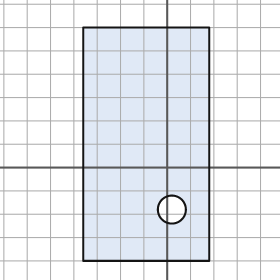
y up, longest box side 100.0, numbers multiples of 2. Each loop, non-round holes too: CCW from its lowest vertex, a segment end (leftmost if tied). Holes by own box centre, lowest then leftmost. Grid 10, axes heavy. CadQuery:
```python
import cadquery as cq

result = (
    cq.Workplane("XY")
    .moveTo(-36.0, -40.0)
    .lineTo(18.0, -40.0)
    .lineTo(18.0, 60.0)
    .lineTo(-36.0, 60.0)
    .close()
    .moveTo(2.0, -18.0)
    .circle(6.0)
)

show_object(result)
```